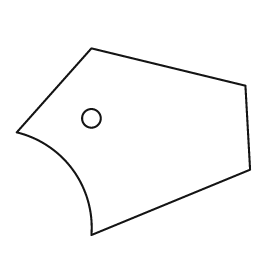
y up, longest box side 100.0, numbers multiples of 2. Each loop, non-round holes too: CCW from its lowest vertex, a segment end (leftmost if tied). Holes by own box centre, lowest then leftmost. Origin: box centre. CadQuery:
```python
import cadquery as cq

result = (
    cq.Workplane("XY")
    .moveTo(-18.0, -40.0)
    .lineTo(50.0, -12.0)
    .lineTo(48.0, 24.0)
    .lineTo(-18.0, 40.0)
    .lineTo(-50.0, 4.0)
    .threePointArc((-26.0, -12.0), (-18.0, -40.0))
    .close()
    .moveTo(-18.0, 10.0)
    .circle(4.0)
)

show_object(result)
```